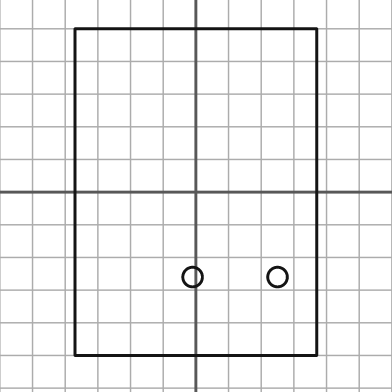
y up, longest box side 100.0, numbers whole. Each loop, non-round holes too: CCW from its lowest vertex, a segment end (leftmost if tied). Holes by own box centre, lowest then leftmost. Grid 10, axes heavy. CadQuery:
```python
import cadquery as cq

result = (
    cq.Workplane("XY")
    .moveTo(-37.0, -50.0)
    .lineTo(37.0, -50.0)
    .lineTo(37.0, 50.0)
    .lineTo(-37.0, 50.0)
    .close()
    .moveTo(-1.0, -26.0)
    .circle(3.0)
    .moveTo(25.0, -26.0)
    .circle(3.0)
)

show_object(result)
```